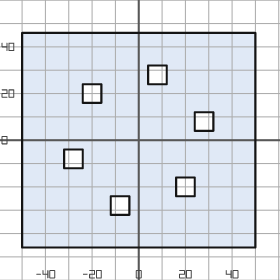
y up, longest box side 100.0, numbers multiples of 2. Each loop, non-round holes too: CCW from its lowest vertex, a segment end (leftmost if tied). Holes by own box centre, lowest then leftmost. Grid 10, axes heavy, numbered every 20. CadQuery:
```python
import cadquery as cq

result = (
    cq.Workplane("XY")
    .moveTo(-50.0, -46.0)
    .lineTo(50.0, -46.0)
    .lineTo(50.0, 46.0)
    .lineTo(-50.0, 46.0)
    .close()
    .moveTo(-12.0, -32.0)
    .lineTo(-4.0, -32.0)
    .lineTo(-4.0, -24.0)
    .lineTo(-12.0, -24.0)
    .close()
    .moveTo(16.0, -24.0)
    .lineTo(24.0, -24.0)
    .lineTo(24.0, -16.0)
    .lineTo(16.0, -16.0)
    .close()
    .moveTo(-32.0, -12.0)
    .lineTo(-24.0, -12.0)
    .lineTo(-24.0, -4.0)
    .lineTo(-32.0, -4.0)
    .close()
    .moveTo(24.0, 4.0)
    .lineTo(32.0, 4.0)
    .lineTo(32.0, 12.0)
    .lineTo(24.0, 12.0)
    .close()
    .moveTo(-24.0, 16.0)
    .lineTo(-16.0, 16.0)
    .lineTo(-16.0, 24.0)
    .lineTo(-24.0, 24.0)
    .close()
    .moveTo(4.0, 24.0)
    .lineTo(12.0, 24.0)
    .lineTo(12.0, 32.0)
    .lineTo(4.0, 32.0)
    .close()
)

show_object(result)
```